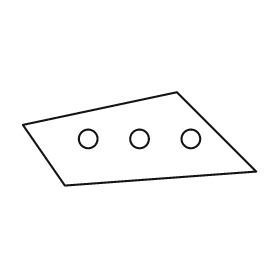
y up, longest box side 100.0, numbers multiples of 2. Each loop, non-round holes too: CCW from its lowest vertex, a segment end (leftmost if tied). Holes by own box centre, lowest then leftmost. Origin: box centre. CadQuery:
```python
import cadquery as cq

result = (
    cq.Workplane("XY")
    .moveTo(-32.0, -20.0)
    .lineTo(50.0, -14.0)
    .lineTo(16.0, 20.0)
    .lineTo(-50.0, 6.0)
    .close()
    .moveTo(-22.0, 0.0)
    .circle(4.0)
    .moveTo(0.0, 0.0)
    .circle(4.0)
    .moveTo(22.0, 0.0)
    .circle(4.0)
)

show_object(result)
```